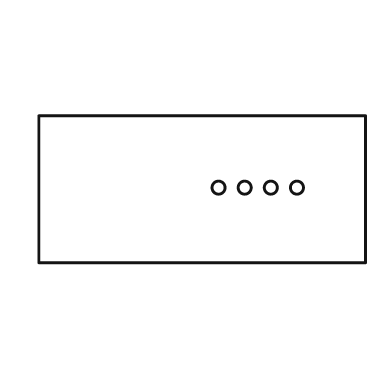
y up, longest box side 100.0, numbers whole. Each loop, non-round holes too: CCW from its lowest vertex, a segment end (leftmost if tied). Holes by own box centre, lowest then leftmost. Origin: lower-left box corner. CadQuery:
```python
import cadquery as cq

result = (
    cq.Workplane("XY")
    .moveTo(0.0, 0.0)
    .lineTo(100.0, 0.0)
    .lineTo(100.0, 45.0)
    .lineTo(0.0, 45.0)
    .close()
    .moveTo(55.0, 23.0)
    .circle(2.0)
    .moveTo(63.0, 23.0)
    .circle(2.0)
    .moveTo(71.0, 23.0)
    .circle(2.0)
    .moveTo(79.0, 23.0)
    .circle(2.0)
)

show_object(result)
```